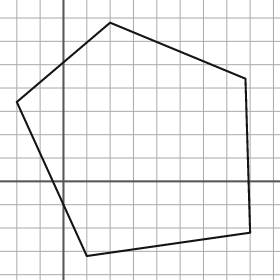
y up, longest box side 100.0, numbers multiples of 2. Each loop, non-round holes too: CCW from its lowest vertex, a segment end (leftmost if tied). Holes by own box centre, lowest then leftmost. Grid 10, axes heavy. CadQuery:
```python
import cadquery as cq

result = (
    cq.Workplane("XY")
    .moveTo(10.0, -32.0)
    .lineTo(80.0, -22.0)
    .lineTo(78.0, 44.0)
    .lineTo(20.0, 68.0)
    .lineTo(-20.0, 34.0)
    .close()
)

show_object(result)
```